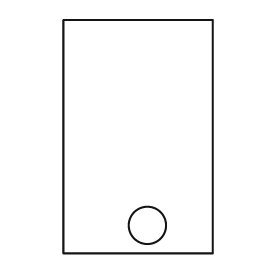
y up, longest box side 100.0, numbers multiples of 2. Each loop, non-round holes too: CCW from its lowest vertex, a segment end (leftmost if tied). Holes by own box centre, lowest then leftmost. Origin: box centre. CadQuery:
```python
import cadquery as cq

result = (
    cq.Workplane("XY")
    .moveTo(-32.0, -50.0)
    .lineTo(32.0, -50.0)
    .lineTo(32.0, 50.0)
    .lineTo(-32.0, 50.0)
    .close()
    .moveTo(4.0, -38.0)
    .circle(8.0)
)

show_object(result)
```